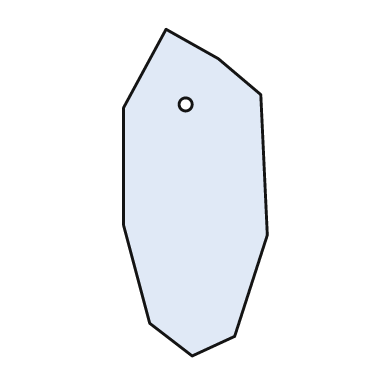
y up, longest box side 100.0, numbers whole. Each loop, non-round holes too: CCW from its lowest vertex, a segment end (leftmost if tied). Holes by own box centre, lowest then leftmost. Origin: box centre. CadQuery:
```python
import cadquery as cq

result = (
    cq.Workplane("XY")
    .moveTo(-1.0, -50.0)
    .lineTo(12.0, -44.0)
    .lineTo(22.0, -13.0)
    .lineTo(20.0, 30.0)
    .lineTo(7.0, 41.0)
    .lineTo(-9.0, 50.0)
    .lineTo(-22.0, 26.0)
    .lineTo(-22.0, -10.0)
    .lineTo(-14.0, -40.0)
    .close()
    .moveTo(-3.0, 27.0)
    .circle(2.0)
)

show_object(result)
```